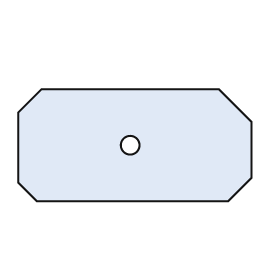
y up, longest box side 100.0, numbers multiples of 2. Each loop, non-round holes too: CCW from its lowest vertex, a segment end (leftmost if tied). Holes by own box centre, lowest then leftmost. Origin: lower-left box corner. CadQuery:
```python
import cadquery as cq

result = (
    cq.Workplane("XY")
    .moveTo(8.0, 0.0)
    .lineTo(90.0, 0.0)
    .lineTo(100.0, 10.0)
    .lineTo(100.0, 34.0)
    .lineTo(86.0, 48.0)
    .lineTo(10.0, 48.0)
    .lineTo(0.0, 38.0)
    .lineTo(0.0, 8.0)
    .close()
    .moveTo(48.0, 24.0)
    .circle(4.0)
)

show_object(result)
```